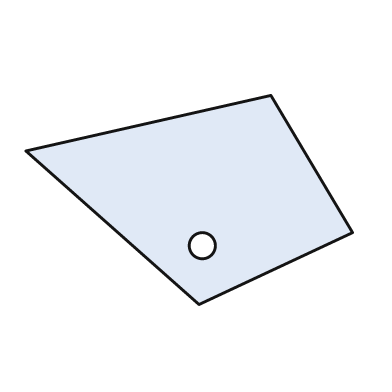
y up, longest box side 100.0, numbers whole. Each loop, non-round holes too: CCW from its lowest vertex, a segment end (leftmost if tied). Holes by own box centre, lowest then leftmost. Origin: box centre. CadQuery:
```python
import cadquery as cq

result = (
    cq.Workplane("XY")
    .moveTo(3.0, -32.0)
    .lineTo(50.0, -10.0)
    .lineTo(25.0, 32.0)
    .lineTo(-50.0, 15.0)
    .close()
    .moveTo(4.0, -14.0)
    .circle(4.0)
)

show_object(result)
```